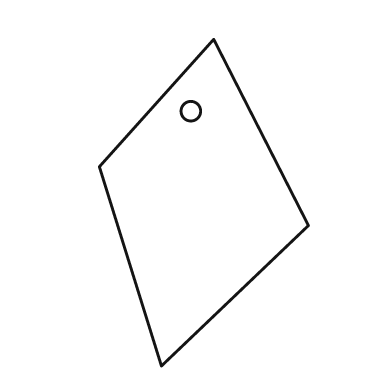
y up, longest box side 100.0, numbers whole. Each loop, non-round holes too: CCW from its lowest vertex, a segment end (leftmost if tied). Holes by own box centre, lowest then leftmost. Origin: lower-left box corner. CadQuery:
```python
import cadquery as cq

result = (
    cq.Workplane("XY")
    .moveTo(19.0, 0.0)
    .lineTo(64.0, 43.0)
    .lineTo(35.0, 100.0)
    .lineTo(0.0, 61.0)
    .close()
    .moveTo(28.0, 78.0)
    .circle(3.0)
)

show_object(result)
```